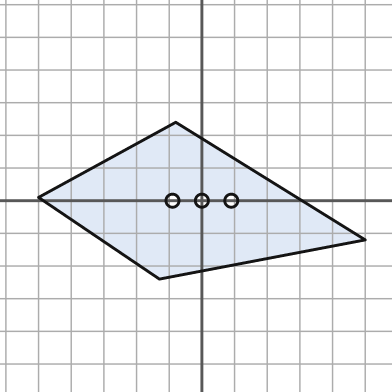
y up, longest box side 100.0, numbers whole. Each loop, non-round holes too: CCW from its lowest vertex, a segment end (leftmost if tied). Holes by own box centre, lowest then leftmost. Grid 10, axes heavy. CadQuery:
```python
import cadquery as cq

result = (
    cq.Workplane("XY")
    .moveTo(-13.0, -24.0)
    .lineTo(50.0, -12.0)
    .lineTo(-8.0, 24.0)
    .lineTo(-50.0, 1.0)
    .close()
    .moveTo(-9.0, 0.0)
    .circle(2.0)
    .moveTo(0.0, 0.0)
    .circle(2.0)
    .moveTo(9.0, 0.0)
    .circle(2.0)
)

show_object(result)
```